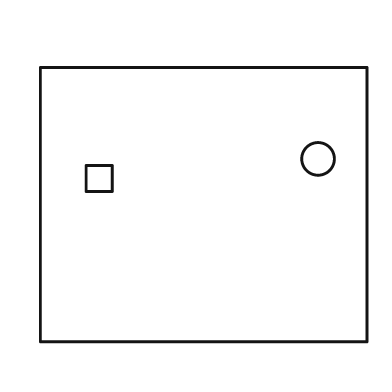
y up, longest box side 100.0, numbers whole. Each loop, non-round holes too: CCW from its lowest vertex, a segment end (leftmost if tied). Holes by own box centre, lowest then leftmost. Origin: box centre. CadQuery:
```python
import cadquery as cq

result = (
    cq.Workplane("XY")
    .moveTo(-50.0, -42.0)
    .lineTo(50.0, -42.0)
    .lineTo(50.0, 42.0)
    .lineTo(-50.0, 42.0)
    .close()
    .moveTo(-36.0, 4.0)
    .lineTo(-28.0, 4.0)
    .lineTo(-28.0, 12.0)
    .lineTo(-36.0, 12.0)
    .close()
    .moveTo(35.0, 14.0)
    .circle(5.0)
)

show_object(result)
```